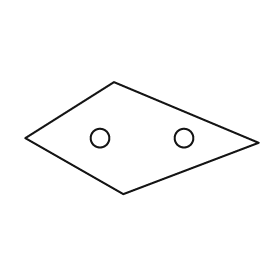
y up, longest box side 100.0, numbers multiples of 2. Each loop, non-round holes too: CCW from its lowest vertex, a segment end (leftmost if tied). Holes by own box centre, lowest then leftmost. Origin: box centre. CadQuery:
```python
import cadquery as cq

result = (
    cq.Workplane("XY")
    .moveTo(-8.0, -24.0)
    .lineTo(50.0, -2.0)
    .lineTo(-12.0, 24.0)
    .lineTo(-50.0, 0.0)
    .close()
    .moveTo(-18.0, 0.0)
    .circle(4.0)
    .moveTo(18.0, 0.0)
    .circle(4.0)
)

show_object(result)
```